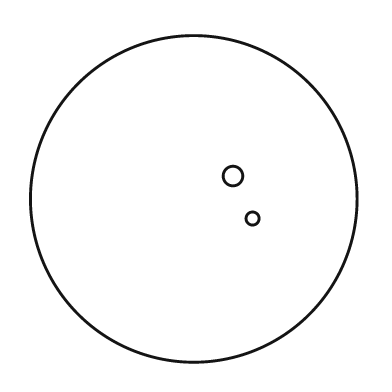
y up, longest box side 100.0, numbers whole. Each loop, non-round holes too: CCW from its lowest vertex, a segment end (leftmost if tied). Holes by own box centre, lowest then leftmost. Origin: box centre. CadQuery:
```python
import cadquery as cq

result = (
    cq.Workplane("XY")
    .moveTo(0.0, 0.0)
    .circle(50.0)
    .moveTo(18.0, -6.0)
    .circle(2.0)
    .moveTo(12.0, 7.0)
    .circle(3.0)
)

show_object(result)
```